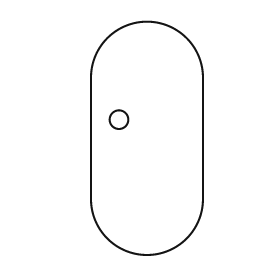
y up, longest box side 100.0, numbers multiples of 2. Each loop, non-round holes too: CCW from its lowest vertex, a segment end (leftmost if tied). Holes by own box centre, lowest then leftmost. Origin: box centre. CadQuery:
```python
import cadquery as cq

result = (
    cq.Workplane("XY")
    .moveTo(-24.0, -26.0)
    .threePointArc((0.0, -50.0), (24.0, -26.0))
    .lineTo(24.0, 26.0)
    .threePointArc((0.0, 50.0), (-24.0, 26.0))
    .close()
    .moveTo(-12.0, 8.0)
    .circle(4.0)
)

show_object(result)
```